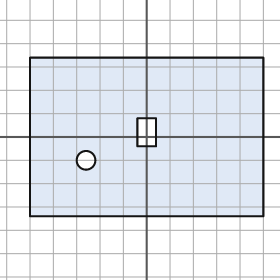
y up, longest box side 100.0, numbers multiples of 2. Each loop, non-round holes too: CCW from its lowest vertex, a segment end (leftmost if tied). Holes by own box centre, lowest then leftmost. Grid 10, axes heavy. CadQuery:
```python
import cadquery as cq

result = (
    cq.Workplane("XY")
    .moveTo(-50.0, -34.0)
    .lineTo(50.0, -34.0)
    .lineTo(50.0, 34.0)
    .lineTo(-50.0, 34.0)
    .close()
    .moveTo(-26.0, -10.0)
    .circle(4.0)
    .moveTo(-4.0, -4.0)
    .lineTo(4.0, -4.0)
    .lineTo(4.0, 8.0)
    .lineTo(-4.0, 8.0)
    .close()
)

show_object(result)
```